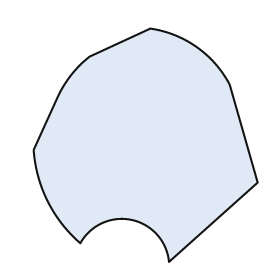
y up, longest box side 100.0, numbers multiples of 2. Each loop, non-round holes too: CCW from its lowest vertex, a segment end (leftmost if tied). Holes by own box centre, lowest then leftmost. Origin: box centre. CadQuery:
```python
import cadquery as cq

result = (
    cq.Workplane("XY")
    .moveTo(10.0, -50.0)
    .lineTo(48.0, -16.0)
    .lineTo(36.0, 26.0)
    .threePointArc((22.0, 42.0), (2.0, 50.0))
    .lineTo(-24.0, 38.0)
    .threePointArc((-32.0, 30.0), (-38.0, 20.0))
    .lineTo(-48.0, -2.0)
    .threePointArc((-42.0, -24.0), (-28.0, -42.0))
    .threePointArc((-6.0, -32.0), (10.0, -50.0))
    .close()
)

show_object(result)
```